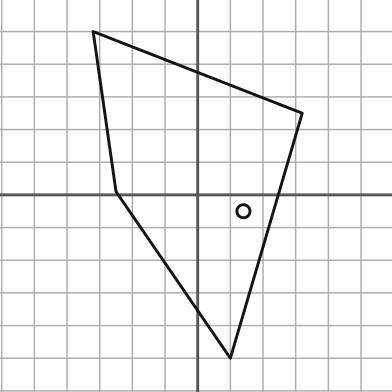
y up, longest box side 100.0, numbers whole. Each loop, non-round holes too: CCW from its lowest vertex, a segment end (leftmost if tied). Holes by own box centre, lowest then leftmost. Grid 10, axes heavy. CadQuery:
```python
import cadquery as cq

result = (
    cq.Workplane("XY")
    .moveTo(10.0, -50.0)
    .lineTo(32.0, 25.0)
    .lineTo(-32.0, 50.0)
    .lineTo(-25.0, 1.0)
    .close()
    .moveTo(14.0, -5.0)
    .circle(2.0)
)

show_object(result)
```